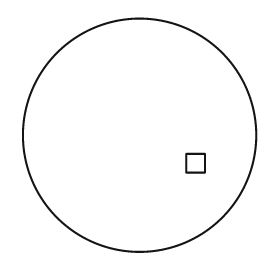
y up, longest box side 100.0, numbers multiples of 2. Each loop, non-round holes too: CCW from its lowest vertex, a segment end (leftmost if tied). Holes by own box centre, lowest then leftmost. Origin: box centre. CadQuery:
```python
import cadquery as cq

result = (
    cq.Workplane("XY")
    .moveTo(0.0, 0.0)
    .circle(50.0)
    .moveTo(20.0, -16.0)
    .lineTo(28.0, -16.0)
    .lineTo(28.0, -8.0)
    .lineTo(20.0, -8.0)
    .close()
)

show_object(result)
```